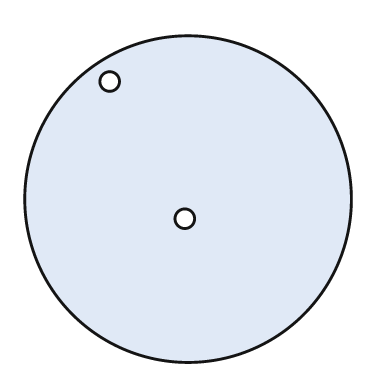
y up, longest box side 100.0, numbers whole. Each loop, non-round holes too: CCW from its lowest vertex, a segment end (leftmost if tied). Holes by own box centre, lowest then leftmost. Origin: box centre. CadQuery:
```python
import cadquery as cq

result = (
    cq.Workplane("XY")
    .moveTo(0.0, 0.0)
    .circle(50.0)
    .moveTo(-1.0, -6.0)
    .circle(3.0)
    .moveTo(-24.0, 36.0)
    .circle(3.0)
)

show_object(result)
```